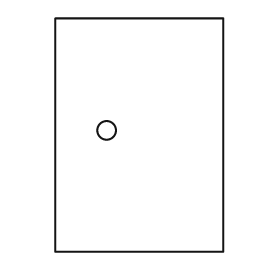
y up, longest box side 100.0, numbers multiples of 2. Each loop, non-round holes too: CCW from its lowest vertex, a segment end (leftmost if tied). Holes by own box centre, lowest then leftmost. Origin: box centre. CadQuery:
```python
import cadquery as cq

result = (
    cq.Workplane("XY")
    .moveTo(-36.0, -50.0)
    .lineTo(36.0, -50.0)
    .lineTo(36.0, 50.0)
    .lineTo(-36.0, 50.0)
    .close()
    .moveTo(-14.0, 2.0)
    .circle(4.0)
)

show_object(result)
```